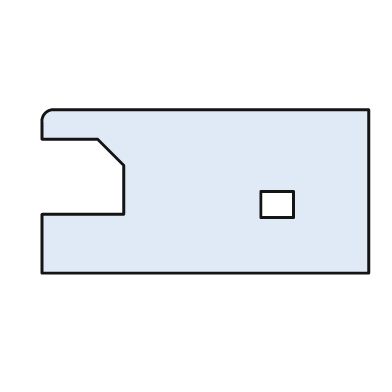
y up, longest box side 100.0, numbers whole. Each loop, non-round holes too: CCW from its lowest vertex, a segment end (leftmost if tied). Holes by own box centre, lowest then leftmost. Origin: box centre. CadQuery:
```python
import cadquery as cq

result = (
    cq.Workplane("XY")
    .moveTo(-50.0, -25.0)
    .lineTo(50.0, -25.0)
    .lineTo(50.0, 25.0)
    .lineTo(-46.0, 25.0)
    .threePointArc((-49.0, 24.0), (-50.0, 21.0))
    .lineTo(-50.0, 16.0)
    .lineTo(-33.0, 16.0)
    .lineTo(-25.0, 8.0)
    .lineTo(-25.0, -7.0)
    .lineTo(-50.0, -7.0)
    .close()
    .moveTo(17.0, -8.0)
    .lineTo(27.0, -8.0)
    .lineTo(27.0, 0.0)
    .lineTo(17.0, 0.0)
    .close()
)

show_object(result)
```